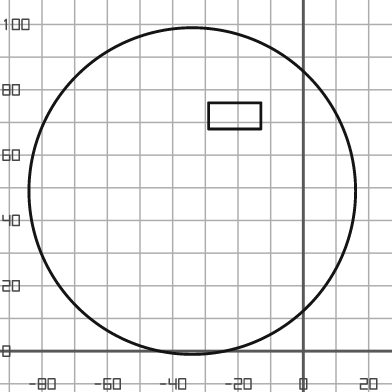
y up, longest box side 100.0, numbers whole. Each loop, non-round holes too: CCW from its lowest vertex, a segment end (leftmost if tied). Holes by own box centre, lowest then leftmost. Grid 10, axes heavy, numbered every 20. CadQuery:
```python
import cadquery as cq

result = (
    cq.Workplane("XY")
    .moveTo(-34.0, 49.0)
    .circle(50.0)
    .moveTo(-29.0, 68.0)
    .lineTo(-13.0, 68.0)
    .lineTo(-13.0, 76.0)
    .lineTo(-29.0, 76.0)
    .close()
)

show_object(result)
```